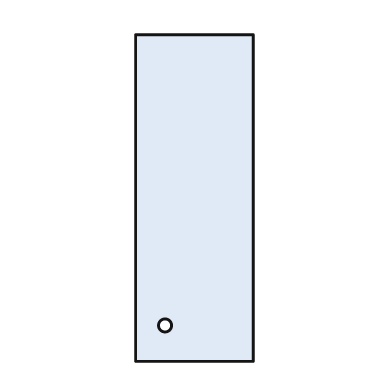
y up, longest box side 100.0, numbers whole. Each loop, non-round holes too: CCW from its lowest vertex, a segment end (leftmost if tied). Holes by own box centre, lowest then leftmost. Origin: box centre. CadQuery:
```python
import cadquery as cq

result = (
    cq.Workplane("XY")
    .moveTo(-18.0, -50.0)
    .lineTo(18.0, -50.0)
    .lineTo(18.0, 50.0)
    .lineTo(-18.0, 50.0)
    .close()
    .moveTo(-9.0, -39.0)
    .circle(2.0)
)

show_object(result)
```